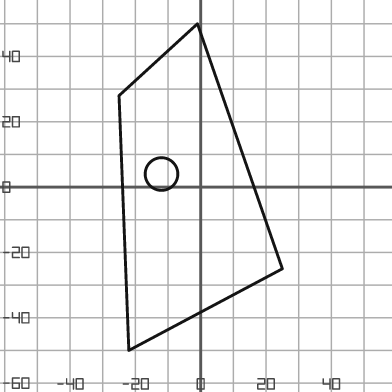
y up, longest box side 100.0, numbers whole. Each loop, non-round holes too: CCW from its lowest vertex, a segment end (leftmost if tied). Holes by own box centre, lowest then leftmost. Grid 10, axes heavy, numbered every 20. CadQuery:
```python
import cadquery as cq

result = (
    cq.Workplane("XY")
    .moveTo(-22.0, -50.0)
    .lineTo(25.0, -25.0)
    .lineTo(-1.0, 50.0)
    .lineTo(-25.0, 28.0)
    .close()
    .moveTo(-12.0, 4.0)
    .circle(5.0)
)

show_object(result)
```